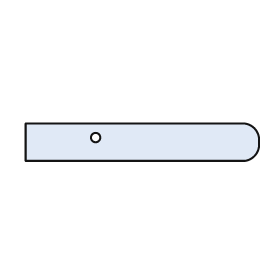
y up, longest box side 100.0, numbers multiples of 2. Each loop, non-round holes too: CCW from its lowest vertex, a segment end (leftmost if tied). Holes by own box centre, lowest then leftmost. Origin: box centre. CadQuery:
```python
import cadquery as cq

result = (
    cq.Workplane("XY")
    .moveTo(-50.0, -8.0)
    .lineTo(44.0, -8.0)
    .threePointArc((48.0, -6.0), (50.0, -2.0))
    .lineTo(50.0, 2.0)
    .threePointArc((48.0, 6.0), (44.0, 8.0))
    .lineTo(-50.0, 8.0)
    .close()
    .moveTo(-20.0, 2.0)
    .circle(2.0)
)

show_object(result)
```